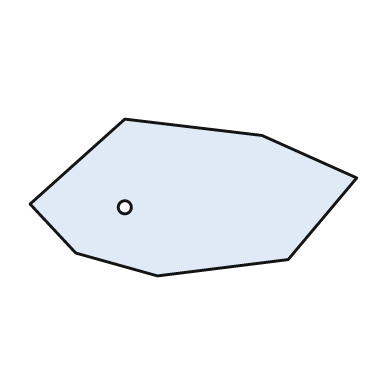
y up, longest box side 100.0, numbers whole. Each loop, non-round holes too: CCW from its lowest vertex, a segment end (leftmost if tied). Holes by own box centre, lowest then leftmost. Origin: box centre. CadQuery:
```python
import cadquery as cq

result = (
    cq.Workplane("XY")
    .moveTo(-11.0, -24.0)
    .lineTo(29.0, -19.0)
    .lineTo(50.0, 6.0)
    .lineTo(21.0, 19.0)
    .lineTo(-21.0, 24.0)
    .lineTo(-50.0, -2.0)
    .lineTo(-36.0, -17.0)
    .close()
    .moveTo(-21.0, -3.0)
    .circle(2.0)
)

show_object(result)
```